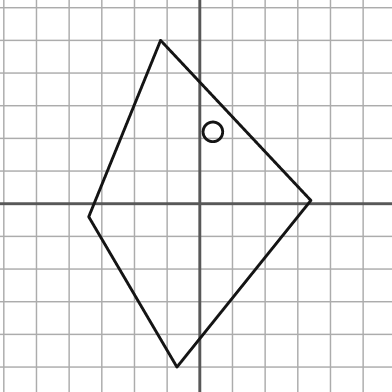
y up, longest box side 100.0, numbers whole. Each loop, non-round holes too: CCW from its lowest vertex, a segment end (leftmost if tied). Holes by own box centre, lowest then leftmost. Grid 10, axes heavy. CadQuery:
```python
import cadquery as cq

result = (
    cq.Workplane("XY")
    .moveTo(-7.0, -50.0)
    .lineTo(34.0, 1.0)
    .lineTo(-12.0, 50.0)
    .lineTo(-34.0, -4.0)
    .close()
    .moveTo(4.0, 22.0)
    .circle(3.0)
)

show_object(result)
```